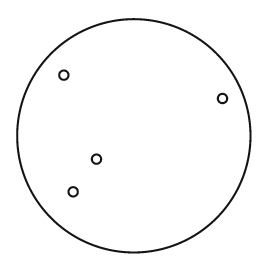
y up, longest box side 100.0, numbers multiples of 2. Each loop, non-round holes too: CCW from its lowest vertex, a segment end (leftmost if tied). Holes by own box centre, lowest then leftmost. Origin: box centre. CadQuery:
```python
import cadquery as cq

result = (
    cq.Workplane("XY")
    .moveTo(0.0, 0.0)
    .circle(50.0)
    .moveTo(-26.0, -24.0)
    .circle(2.0)
    .moveTo(-16.0, -10.0)
    .circle(2.0)
    .moveTo(38.0, 16.0)
    .circle(2.0)
    .moveTo(-30.0, 26.0)
    .circle(2.0)
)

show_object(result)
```